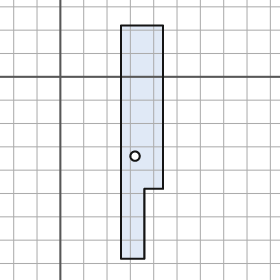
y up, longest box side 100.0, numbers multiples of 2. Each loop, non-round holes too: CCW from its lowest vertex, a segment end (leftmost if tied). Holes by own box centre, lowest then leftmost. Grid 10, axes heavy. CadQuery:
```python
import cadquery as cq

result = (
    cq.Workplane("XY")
    .moveTo(26.0, -78.0)
    .lineTo(36.0, -78.0)
    .lineTo(36.0, -48.0)
    .lineTo(44.0, -48.0)
    .lineTo(44.0, 22.0)
    .lineTo(26.0, 22.0)
    .close()
    .moveTo(32.0, -34.0)
    .circle(2.0)
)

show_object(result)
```